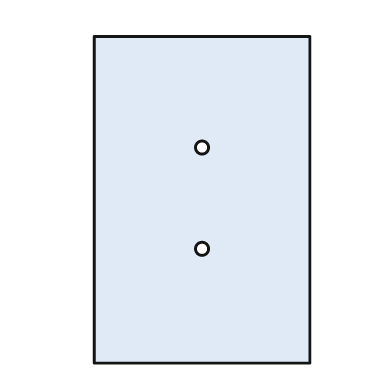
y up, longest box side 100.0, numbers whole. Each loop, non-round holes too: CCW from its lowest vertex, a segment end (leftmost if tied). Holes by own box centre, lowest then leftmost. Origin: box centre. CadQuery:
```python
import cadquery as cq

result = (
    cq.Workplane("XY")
    .moveTo(-33.0, -50.0)
    .lineTo(33.0, -50.0)
    .lineTo(33.0, 50.0)
    .lineTo(-33.0, 50.0)
    .close()
    .moveTo(0.0, -15.0)
    .circle(2.0)
    .moveTo(0.0, 16.0)
    .circle(2.0)
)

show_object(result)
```